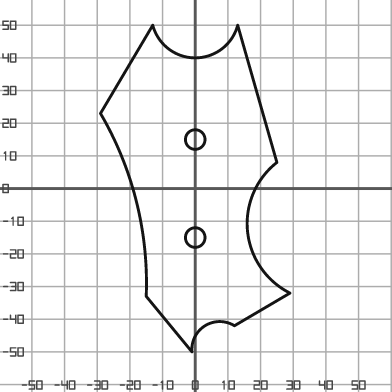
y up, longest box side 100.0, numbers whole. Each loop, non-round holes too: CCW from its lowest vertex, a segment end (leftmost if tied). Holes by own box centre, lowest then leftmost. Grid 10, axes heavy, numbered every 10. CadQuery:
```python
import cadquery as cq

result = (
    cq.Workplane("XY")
    .moveTo(-1.0, -50.0)
    .threePointArc((3.0, -42.0), (12.0, -42.0))
    .lineTo(29.0, -32.0)
    .threePointArc((16.0, -13.0), (25.0, 8.0))
    .lineTo(13.0, 50.0)
    .threePointArc((0.0, 40.0), (-13.0, 50.0))
    .lineTo(-29.0, 23.0)
    .threePointArc((-18.0, -4.0), (-15.0, -33.0))
    .close()
    .moveTo(0.0, -15.0)
    .circle(3.0)
    .moveTo(0.0, 15.0)
    .circle(3.0)
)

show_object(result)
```